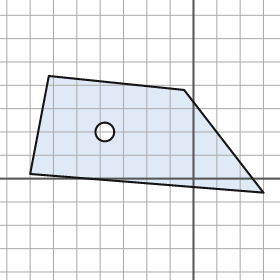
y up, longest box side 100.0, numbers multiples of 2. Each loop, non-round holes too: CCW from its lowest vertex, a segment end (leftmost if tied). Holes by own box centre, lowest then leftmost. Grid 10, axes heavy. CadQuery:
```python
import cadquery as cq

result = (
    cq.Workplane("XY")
    .moveTo(30.0, -6.0)
    .lineTo(-4.0, 38.0)
    .lineTo(-62.0, 44.0)
    .lineTo(-70.0, 2.0)
    .close()
    .moveTo(-38.0, 20.0)
    .circle(4.0)
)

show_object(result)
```